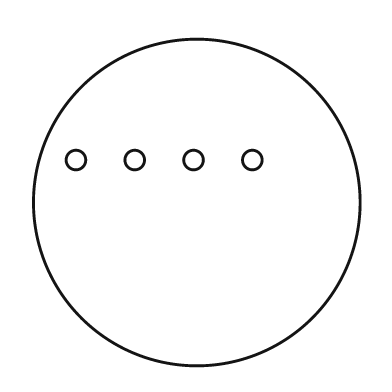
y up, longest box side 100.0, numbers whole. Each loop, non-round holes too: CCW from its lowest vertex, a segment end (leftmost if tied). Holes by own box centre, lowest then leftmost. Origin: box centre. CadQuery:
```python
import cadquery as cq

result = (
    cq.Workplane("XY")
    .moveTo(0.0, 0.0)
    .circle(50.0)
    .moveTo(-37.0, 13.0)
    .circle(3.0)
    .moveTo(-19.0, 13.0)
    .circle(3.0)
    .moveTo(-1.0, 13.0)
    .circle(3.0)
    .moveTo(17.0, 13.0)
    .circle(3.0)
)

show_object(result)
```